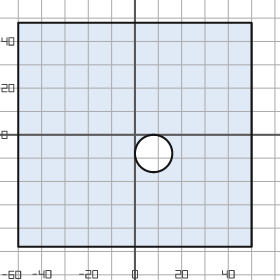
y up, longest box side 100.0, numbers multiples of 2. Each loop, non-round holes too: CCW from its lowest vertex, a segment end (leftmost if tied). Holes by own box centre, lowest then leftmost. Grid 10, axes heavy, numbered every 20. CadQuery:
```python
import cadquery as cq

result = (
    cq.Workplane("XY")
    .moveTo(-50.0, -48.0)
    .lineTo(50.0, -48.0)
    .lineTo(50.0, 48.0)
    .lineTo(-50.0, 48.0)
    .close()
    .moveTo(8.0, -8.0)
    .circle(8.0)
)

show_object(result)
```